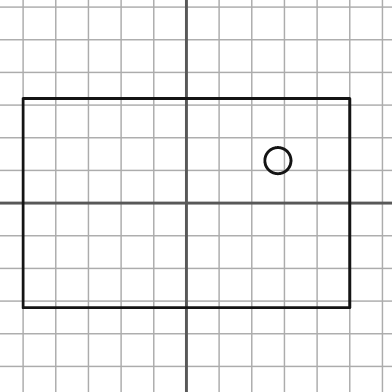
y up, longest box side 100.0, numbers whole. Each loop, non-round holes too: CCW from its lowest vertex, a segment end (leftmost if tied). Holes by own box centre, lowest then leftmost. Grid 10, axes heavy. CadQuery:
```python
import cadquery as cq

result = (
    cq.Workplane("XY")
    .moveTo(-50.0, -32.0)
    .lineTo(50.0, -32.0)
    .lineTo(50.0, 32.0)
    .lineTo(-50.0, 32.0)
    .close()
    .moveTo(28.0, 13.0)
    .circle(4.0)
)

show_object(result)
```